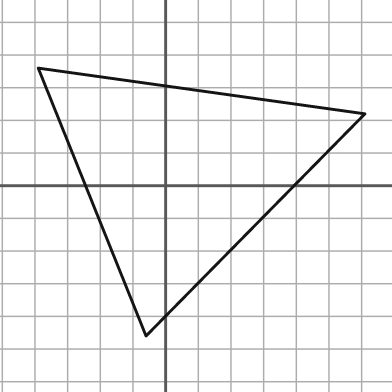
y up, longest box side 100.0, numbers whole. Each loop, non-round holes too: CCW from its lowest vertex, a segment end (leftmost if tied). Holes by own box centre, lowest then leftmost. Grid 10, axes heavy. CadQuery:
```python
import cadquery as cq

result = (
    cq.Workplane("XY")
    .moveTo(-6.0, -46.0)
    .lineTo(61.0, 22.0)
    .lineTo(-39.0, 36.0)
    .close()
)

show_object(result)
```